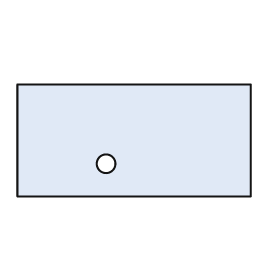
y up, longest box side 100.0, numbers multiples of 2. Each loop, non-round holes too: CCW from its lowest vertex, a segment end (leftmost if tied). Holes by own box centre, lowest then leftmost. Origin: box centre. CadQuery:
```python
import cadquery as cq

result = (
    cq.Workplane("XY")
    .moveTo(-50.0, -24.0)
    .lineTo(50.0, -24.0)
    .lineTo(50.0, 24.0)
    .lineTo(-50.0, 24.0)
    .close()
    .moveTo(-12.0, -10.0)
    .circle(4.0)
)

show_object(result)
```